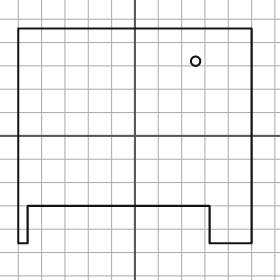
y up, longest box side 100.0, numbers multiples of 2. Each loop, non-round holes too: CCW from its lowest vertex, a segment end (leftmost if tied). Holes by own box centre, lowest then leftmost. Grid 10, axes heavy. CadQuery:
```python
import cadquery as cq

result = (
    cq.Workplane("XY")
    .moveTo(-50.0, -46.0)
    .lineTo(-46.0, -46.0)
    .lineTo(-46.0, -30.0)
    .lineTo(32.0, -30.0)
    .lineTo(32.0, -46.0)
    .lineTo(50.0, -46.0)
    .lineTo(50.0, 46.0)
    .lineTo(-50.0, 46.0)
    .close()
    .moveTo(26.0, 32.0)
    .circle(2.0)
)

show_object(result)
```